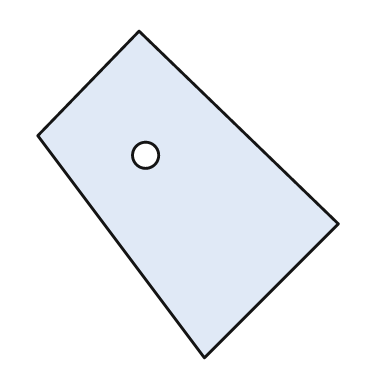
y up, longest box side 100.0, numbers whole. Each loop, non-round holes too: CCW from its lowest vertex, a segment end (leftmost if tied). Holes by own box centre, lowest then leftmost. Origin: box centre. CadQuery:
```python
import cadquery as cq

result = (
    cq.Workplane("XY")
    .moveTo(5.0, -50.0)
    .lineTo(46.0, -9.0)
    .lineTo(-15.0, 50.0)
    .lineTo(-46.0, 18.0)
    .close()
    .moveTo(-13.0, 12.0)
    .circle(4.0)
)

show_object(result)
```